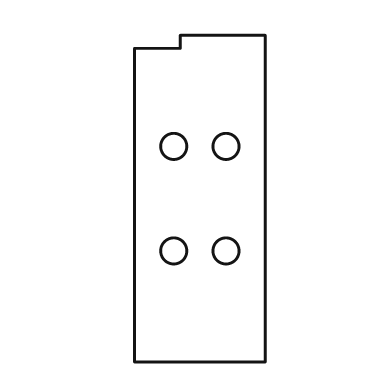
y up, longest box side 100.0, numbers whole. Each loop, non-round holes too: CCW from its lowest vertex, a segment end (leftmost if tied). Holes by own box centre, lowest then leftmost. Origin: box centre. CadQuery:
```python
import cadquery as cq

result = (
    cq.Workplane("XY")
    .moveTo(-20.0, -50.0)
    .lineTo(20.0, -50.0)
    .lineTo(20.0, 50.0)
    .lineTo(-6.0, 50.0)
    .lineTo(-6.0, 46.0)
    .lineTo(-20.0, 46.0)
    .close()
    .moveTo(-8.0, -16.0)
    .circle(4.0)
    .moveTo(8.0, -16.0)
    .circle(4.0)
    .moveTo(-8.0, 16.0)
    .circle(4.0)
    .moveTo(8.0, 16.0)
    .circle(4.0)
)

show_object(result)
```